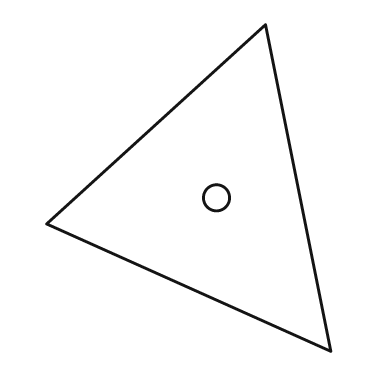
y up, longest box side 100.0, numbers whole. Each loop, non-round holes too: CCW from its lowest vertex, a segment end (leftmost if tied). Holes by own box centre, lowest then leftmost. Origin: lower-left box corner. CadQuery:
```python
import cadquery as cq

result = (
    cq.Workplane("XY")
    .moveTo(87.0, 0.0)
    .lineTo(67.0, 100.0)
    .lineTo(0.0, 39.0)
    .close()
    .moveTo(52.0, 47.0)
    .circle(4.0)
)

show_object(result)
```